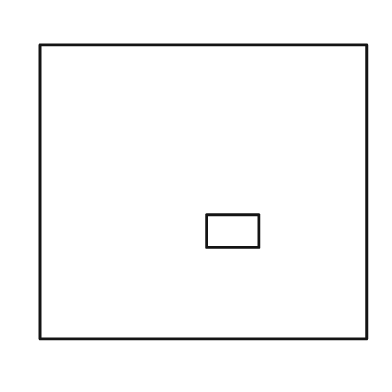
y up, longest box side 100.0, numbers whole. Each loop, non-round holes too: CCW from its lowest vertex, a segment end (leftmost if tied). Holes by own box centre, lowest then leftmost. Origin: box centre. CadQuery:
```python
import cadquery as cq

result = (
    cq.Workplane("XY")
    .moveTo(-50.0, -45.0)
    .lineTo(50.0, -45.0)
    .lineTo(50.0, 45.0)
    .lineTo(-50.0, 45.0)
    .close()
    .moveTo(1.0, -17.0)
    .lineTo(17.0, -17.0)
    .lineTo(17.0, -7.0)
    .lineTo(1.0, -7.0)
    .close()
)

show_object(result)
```